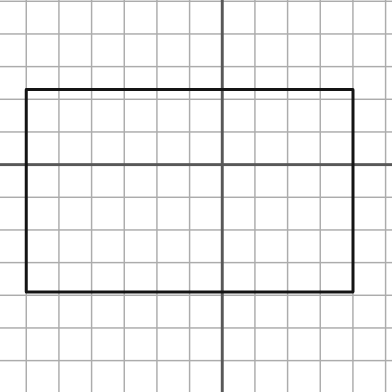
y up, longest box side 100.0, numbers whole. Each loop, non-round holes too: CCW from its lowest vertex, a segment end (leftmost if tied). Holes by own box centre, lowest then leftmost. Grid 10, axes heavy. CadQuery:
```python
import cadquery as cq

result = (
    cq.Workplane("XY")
    .moveTo(-60.0, -39.0)
    .lineTo(40.0, -39.0)
    .lineTo(40.0, 23.0)
    .lineTo(-60.0, 23.0)
    .close()
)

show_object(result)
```